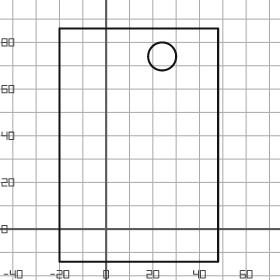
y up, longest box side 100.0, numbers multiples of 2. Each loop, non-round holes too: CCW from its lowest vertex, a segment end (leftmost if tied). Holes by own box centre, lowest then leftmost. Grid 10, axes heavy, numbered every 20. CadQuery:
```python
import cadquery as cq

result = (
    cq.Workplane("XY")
    .moveTo(-20.0, -14.0)
    .lineTo(48.0, -14.0)
    .lineTo(48.0, 86.0)
    .lineTo(-20.0, 86.0)
    .close()
    .moveTo(24.0, 74.0)
    .circle(6.0)
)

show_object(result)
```